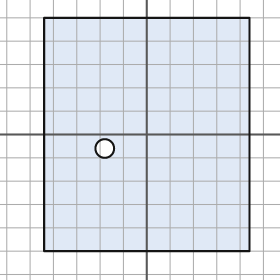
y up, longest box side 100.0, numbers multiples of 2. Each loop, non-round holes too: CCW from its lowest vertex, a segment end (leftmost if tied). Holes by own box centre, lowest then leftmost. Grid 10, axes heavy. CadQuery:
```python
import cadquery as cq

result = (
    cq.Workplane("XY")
    .moveTo(-44.0, -50.0)
    .lineTo(44.0, -50.0)
    .lineTo(44.0, 50.0)
    .lineTo(-44.0, 50.0)
    .close()
    .moveTo(-18.0, -6.0)
    .circle(4.0)
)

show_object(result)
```